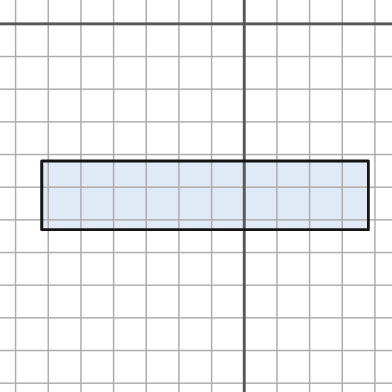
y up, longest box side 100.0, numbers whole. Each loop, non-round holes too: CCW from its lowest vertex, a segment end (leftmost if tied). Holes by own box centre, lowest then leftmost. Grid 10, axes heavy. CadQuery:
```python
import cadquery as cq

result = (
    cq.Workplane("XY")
    .moveTo(-62.0, -63.0)
    .lineTo(38.0, -63.0)
    .lineTo(38.0, -42.0)
    .lineTo(-62.0, -42.0)
    .close()
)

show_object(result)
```